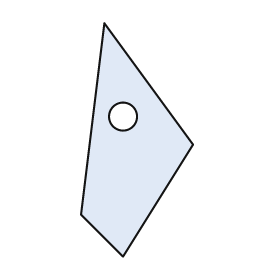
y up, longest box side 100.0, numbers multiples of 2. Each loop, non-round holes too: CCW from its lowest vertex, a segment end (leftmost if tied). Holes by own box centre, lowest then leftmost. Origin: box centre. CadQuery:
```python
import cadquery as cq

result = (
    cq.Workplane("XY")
    .moveTo(-6.0, -50.0)
    .lineTo(24.0, -2.0)
    .lineTo(-14.0, 50.0)
    .lineTo(-24.0, -32.0)
    .close()
    .moveTo(-6.0, 10.0)
    .circle(6.0)
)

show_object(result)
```